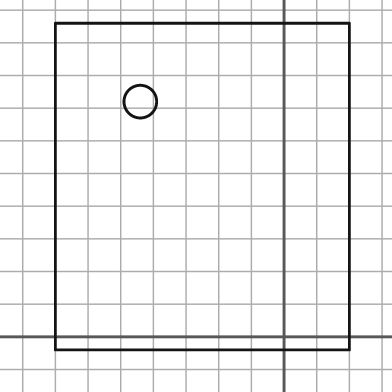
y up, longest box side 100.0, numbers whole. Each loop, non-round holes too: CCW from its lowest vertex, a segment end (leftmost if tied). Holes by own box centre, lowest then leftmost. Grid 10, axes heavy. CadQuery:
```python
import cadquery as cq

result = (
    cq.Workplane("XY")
    .moveTo(-70.0, -4.0)
    .lineTo(20.0, -4.0)
    .lineTo(20.0, 96.0)
    .lineTo(-70.0, 96.0)
    .close()
    .moveTo(-44.0, 72.0)
    .circle(5.0)
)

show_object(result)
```